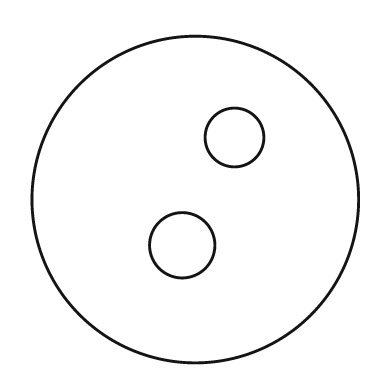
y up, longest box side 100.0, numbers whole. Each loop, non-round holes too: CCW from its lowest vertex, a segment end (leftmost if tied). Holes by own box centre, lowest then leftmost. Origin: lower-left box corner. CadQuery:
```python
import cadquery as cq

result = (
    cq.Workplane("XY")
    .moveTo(50.0, 50.0)
    .circle(50.0)
    .moveTo(46.0, 36.0)
    .circle(10.0)
    .moveTo(62.0, 69.0)
    .circle(9.0)
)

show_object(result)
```